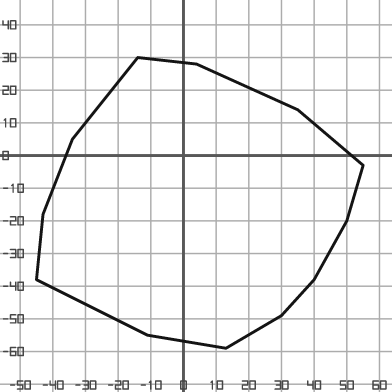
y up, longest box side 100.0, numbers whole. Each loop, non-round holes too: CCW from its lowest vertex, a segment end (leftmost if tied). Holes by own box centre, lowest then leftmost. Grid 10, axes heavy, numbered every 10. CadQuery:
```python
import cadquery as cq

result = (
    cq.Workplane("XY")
    .moveTo(13.0, -59.0)
    .lineTo(30.0, -49.0)
    .lineTo(40.0, -38.0)
    .lineTo(50.0, -20.0)
    .lineTo(55.0, -3.0)
    .lineTo(35.0, 14.0)
    .lineTo(4.0, 28.0)
    .lineTo(-14.0, 30.0)
    .lineTo(-34.0, 5.0)
    .lineTo(-43.0, -18.0)
    .lineTo(-45.0, -38.0)
    .lineTo(-11.0, -55.0)
    .close()
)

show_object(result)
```